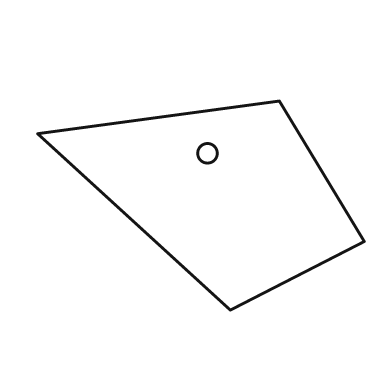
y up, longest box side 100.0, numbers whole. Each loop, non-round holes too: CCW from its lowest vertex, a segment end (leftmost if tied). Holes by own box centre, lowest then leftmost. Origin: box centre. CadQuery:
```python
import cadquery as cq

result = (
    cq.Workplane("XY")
    .moveTo(9.0, -32.0)
    .lineTo(50.0, -11.0)
    .lineTo(24.0, 32.0)
    .lineTo(-50.0, 22.0)
    .close()
    .moveTo(2.0, 16.0)
    .circle(3.0)
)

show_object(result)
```